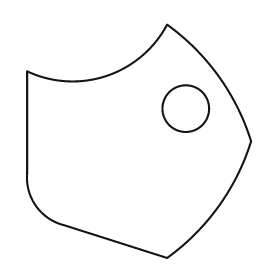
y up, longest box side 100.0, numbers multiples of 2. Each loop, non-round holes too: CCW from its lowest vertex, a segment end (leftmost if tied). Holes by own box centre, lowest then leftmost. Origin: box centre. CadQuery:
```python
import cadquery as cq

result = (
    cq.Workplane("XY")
    .moveTo(12.0, -50.0)
    .threePointArc((34.0, -28.0), (48.0, 0.0))
    .threePointArc((34.0, 28.0), (12.0, 50.0))
    .threePointArc((-14.0, 28.0), (-48.0, 30.0))
    .lineTo(-48.0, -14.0)
    .threePointArc((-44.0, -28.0), (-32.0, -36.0))
    .close()
    .moveTo(20.0, 14.0)
    .circle(10.0)
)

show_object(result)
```